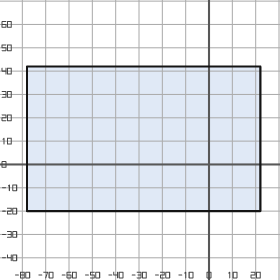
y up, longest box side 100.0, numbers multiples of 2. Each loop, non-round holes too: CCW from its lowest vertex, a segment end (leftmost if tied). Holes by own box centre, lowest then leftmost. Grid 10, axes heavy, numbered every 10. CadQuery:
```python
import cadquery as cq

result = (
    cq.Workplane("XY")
    .moveTo(-78.0, -20.0)
    .lineTo(22.0, -20.0)
    .lineTo(22.0, 42.0)
    .lineTo(-78.0, 42.0)
    .close()
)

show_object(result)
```